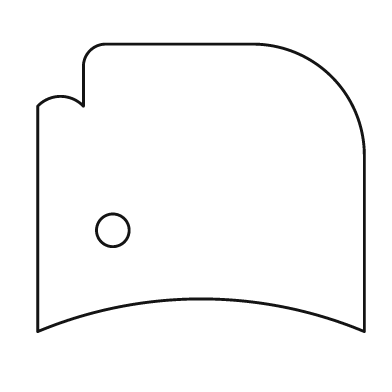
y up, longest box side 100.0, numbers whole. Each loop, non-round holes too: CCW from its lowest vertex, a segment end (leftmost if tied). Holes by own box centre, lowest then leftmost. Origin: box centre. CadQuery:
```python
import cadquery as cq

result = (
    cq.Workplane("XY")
    .moveTo(-50.0, -44.0)
    .threePointArc((0.0, -34.0), (50.0, -44.0))
    .lineTo(50.0, 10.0)
    .threePointArc((40.0, 34.0), (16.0, 44.0))
    .lineTo(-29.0, 44.0)
    .threePointArc((-34.0, 42.0), (-36.0, 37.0))
    .lineTo(-36.0, 25.0)
    .threePointArc((-43.0, 28.0), (-50.0, 25.0))
    .close()
    .moveTo(-27.0, -13.0)
    .circle(5.0)
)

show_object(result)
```